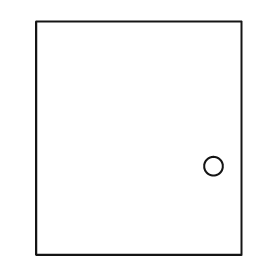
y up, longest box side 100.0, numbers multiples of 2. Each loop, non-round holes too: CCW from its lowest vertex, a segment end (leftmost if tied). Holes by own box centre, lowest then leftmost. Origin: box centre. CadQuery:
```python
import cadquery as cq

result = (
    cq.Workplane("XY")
    .moveTo(-44.0, -50.0)
    .lineTo(44.0, -50.0)
    .lineTo(44.0, 50.0)
    .lineTo(-44.0, 50.0)
    .close()
    .moveTo(32.0, -12.0)
    .circle(4.0)
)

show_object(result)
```